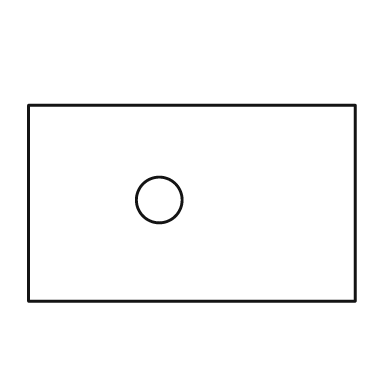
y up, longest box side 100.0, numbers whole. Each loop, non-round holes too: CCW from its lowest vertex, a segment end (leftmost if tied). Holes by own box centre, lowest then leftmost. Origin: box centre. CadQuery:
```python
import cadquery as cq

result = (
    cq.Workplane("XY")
    .moveTo(-50.0, -30.0)
    .lineTo(50.0, -30.0)
    .lineTo(50.0, 30.0)
    .lineTo(-50.0, 30.0)
    .close()
    .moveTo(-10.0, 1.0)
    .circle(7.0)
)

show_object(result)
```